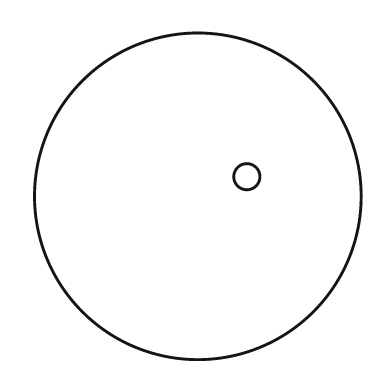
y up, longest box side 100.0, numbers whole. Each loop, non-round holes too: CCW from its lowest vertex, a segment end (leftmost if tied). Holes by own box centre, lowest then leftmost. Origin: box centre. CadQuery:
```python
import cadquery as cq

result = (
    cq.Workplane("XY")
    .moveTo(0.0, 0.0)
    .circle(50.0)
    .moveTo(15.0, 6.0)
    .circle(4.0)
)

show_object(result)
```